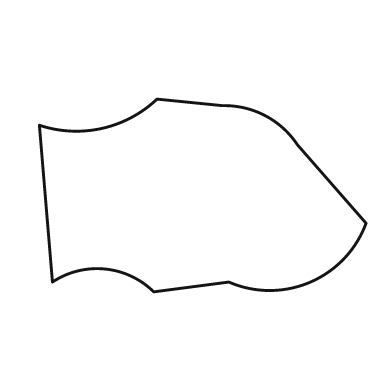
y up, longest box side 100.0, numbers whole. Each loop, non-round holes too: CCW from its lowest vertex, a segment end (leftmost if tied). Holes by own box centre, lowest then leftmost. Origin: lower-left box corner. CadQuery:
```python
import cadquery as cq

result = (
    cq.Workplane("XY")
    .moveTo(35.0, 0.0)
    .lineTo(58.0, 3.0)
    .threePointArc((83.0, 3.0), (100.0, 21.0))
    .lineTo(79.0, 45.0)
    .threePointArc((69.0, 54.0), (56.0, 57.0))
    .lineTo(36.0, 59.0)
    .threePointArc((19.0, 50.0), (0.0, 51.0))
    .lineTo(4.0, 3.0)
    .threePointArc((20.0, 7.0), (35.0, 0.0))
    .close()
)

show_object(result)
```